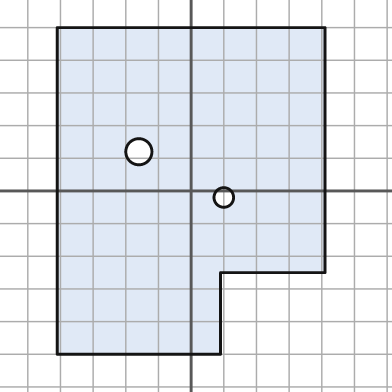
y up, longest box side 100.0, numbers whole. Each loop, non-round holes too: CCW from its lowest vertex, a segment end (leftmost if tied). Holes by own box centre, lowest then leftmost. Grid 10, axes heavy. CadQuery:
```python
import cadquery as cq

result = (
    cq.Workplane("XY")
    .moveTo(-41.0, -50.0)
    .lineTo(9.0, -50.0)
    .lineTo(9.0, -25.0)
    .lineTo(41.0, -25.0)
    .lineTo(41.0, 50.0)
    .lineTo(-41.0, 50.0)
    .close()
    .moveTo(10.0, -2.0)
    .circle(3.0)
    .moveTo(-16.0, 12.0)
    .circle(4.0)
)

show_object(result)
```